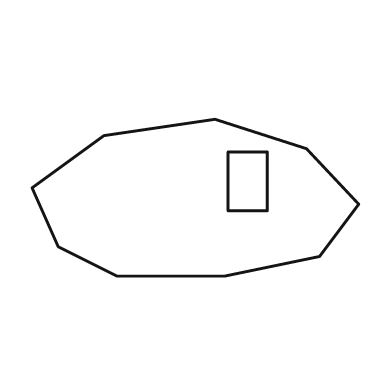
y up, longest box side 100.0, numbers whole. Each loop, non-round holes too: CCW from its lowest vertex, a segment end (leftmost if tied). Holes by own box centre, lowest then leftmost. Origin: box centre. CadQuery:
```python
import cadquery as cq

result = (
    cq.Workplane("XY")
    .moveTo(-24.0, -24.0)
    .lineTo(9.0, -24.0)
    .lineTo(38.0, -18.0)
    .lineTo(50.0, -2.0)
    .lineTo(34.0, 15.0)
    .lineTo(6.0, 24.0)
    .lineTo(-28.0, 19.0)
    .lineTo(-50.0, 3.0)
    .lineTo(-42.0, -15.0)
    .close()
    .moveTo(10.0, -4.0)
    .lineTo(22.0, -4.0)
    .lineTo(22.0, 14.0)
    .lineTo(10.0, 14.0)
    .close()
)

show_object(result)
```